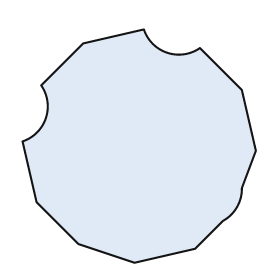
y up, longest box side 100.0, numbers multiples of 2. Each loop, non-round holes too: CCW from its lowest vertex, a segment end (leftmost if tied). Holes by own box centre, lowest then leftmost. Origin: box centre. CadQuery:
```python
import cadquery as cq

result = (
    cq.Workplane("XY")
    .moveTo(-2.0, -50.0)
    .lineTo(24.0, -44.0)
    .lineTo(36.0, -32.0)
    .threePointArc((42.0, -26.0), (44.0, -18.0))
    .lineTo(50.0, -2.0)
    .lineTo(44.0, 24.0)
    .lineTo(26.0, 42.0)
    .threePointArc((12.0, 40.0), (2.0, 50.0))
    .lineTo(-24.0, 44.0)
    .lineTo(-42.0, 26.0)
    .threePointArc((-40.0, 12.0), (-50.0, 2.0))
    .lineTo(-44.0, -24.0)
    .lineTo(-26.0, -42.0)
    .close()
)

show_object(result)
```